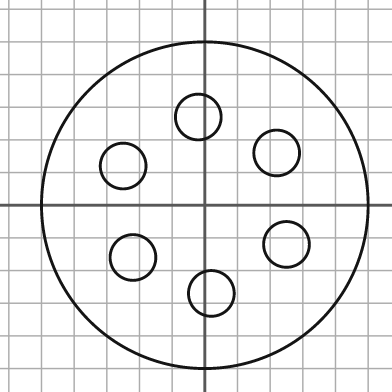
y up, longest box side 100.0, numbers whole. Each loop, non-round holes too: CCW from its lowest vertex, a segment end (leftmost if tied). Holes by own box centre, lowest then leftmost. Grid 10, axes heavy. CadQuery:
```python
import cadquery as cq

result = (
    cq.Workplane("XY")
    .moveTo(0.0, 0.0)
    .circle(50.0)
    .moveTo(2.0, -27.0)
    .circle(7.0)
    .moveTo(-22.0, -16.0)
    .circle(7.0)
    .moveTo(25.0, -12.0)
    .circle(7.0)
    .moveTo(-25.0, 12.0)
    .circle(7.0)
    .moveTo(22.0, 16.0)
    .circle(7.0)
    .moveTo(-2.0, 27.0)
    .circle(7.0)
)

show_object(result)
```